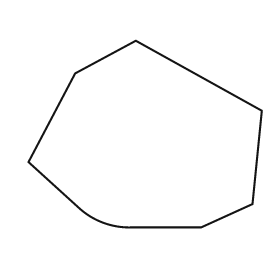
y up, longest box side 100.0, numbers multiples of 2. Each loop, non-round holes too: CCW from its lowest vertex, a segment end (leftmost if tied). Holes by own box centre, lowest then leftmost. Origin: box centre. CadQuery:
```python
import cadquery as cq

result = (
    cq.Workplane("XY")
    .moveTo(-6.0, -40.0)
    .lineTo(24.0, -40.0)
    .lineTo(46.0, -30.0)
    .lineTo(50.0, 10.0)
    .lineTo(-4.0, 40.0)
    .lineTo(-30.0, 26.0)
    .lineTo(-50.0, -12.0)
    .lineTo(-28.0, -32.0)
    .threePointArc((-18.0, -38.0), (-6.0, -40.0))
    .close()
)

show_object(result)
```